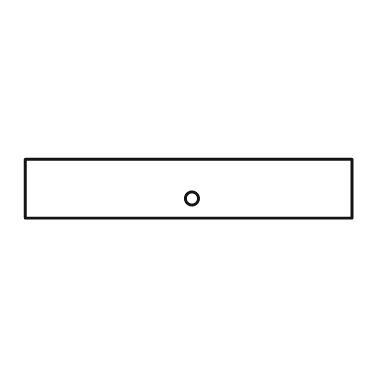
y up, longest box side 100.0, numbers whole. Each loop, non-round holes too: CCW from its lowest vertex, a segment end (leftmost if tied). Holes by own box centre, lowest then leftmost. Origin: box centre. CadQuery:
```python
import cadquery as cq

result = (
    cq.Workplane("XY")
    .moveTo(-50.0, -9.0)
    .lineTo(50.0, -9.0)
    .lineTo(50.0, 9.0)
    .lineTo(-50.0, 9.0)
    .close()
    .moveTo(1.0, -3.0)
    .circle(2.0)
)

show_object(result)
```